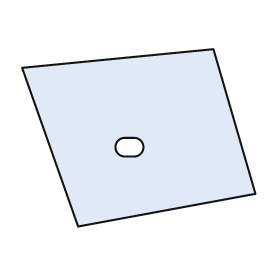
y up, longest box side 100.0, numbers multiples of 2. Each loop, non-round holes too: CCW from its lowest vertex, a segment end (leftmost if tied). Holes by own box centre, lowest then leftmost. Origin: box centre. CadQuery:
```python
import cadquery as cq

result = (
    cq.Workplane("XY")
    .moveTo(-26.0, -38.0)
    .lineTo(50.0, -24.0)
    .lineTo(32.0, 38.0)
    .lineTo(-50.0, 30.0)
    .close()
    .moveTo(-6.0, -8.0)
    .lineTo(-2.0, -8.0)
    .threePointArc((2.0, -4.0), (-2.0, 0.0))
    .lineTo(-6.0, 0.0)
    .threePointArc((-10.0, -4.0), (-6.0, -8.0))
    .close()
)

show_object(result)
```